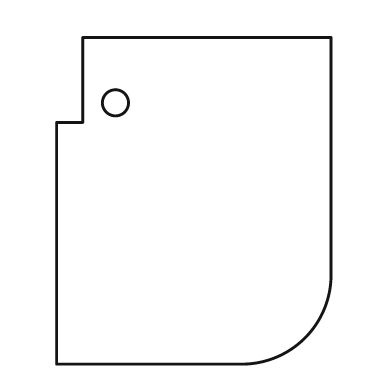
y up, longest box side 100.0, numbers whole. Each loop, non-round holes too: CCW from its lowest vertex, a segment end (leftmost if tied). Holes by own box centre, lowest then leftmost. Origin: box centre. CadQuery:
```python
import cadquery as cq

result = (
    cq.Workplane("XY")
    .moveTo(-42.0, -50.0)
    .lineTo(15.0, -50.0)
    .threePointArc((34.0, -42.0), (42.0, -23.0))
    .lineTo(42.0, 50.0)
    .lineTo(-34.0, 50.0)
    .lineTo(-34.0, 24.0)
    .lineTo(-42.0, 24.0)
    .close()
    .moveTo(-24.0, 30.0)
    .circle(4.0)
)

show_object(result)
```